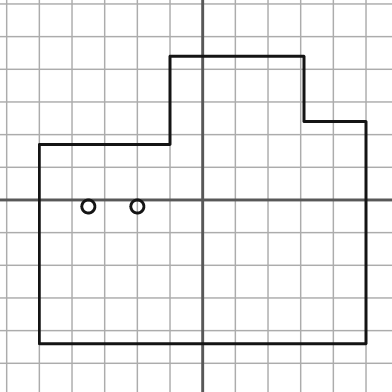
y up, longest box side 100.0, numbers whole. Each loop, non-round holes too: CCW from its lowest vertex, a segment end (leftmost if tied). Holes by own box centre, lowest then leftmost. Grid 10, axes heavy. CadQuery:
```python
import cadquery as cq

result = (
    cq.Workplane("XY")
    .moveTo(-50.0, -44.0)
    .lineTo(50.0, -44.0)
    .lineTo(50.0, 24.0)
    .lineTo(31.0, 24.0)
    .lineTo(31.0, 44.0)
    .lineTo(-10.0, 44.0)
    .lineTo(-10.0, 17.0)
    .lineTo(-50.0, 17.0)
    .close()
    .moveTo(-35.0, -2.0)
    .circle(2.0)
    .moveTo(-20.0, -2.0)
    .circle(2.0)
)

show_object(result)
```